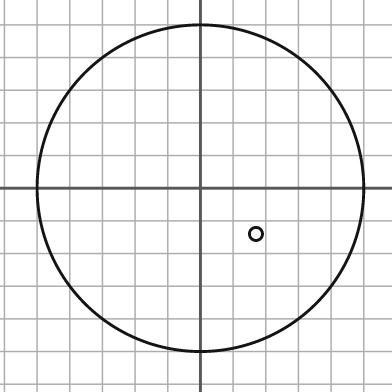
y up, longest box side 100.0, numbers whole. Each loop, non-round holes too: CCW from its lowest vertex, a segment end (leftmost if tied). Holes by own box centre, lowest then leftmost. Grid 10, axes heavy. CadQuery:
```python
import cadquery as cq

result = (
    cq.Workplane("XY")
    .moveTo(0.0, 0.0)
    .circle(50.0)
    .moveTo(17.0, -14.0)
    .circle(2.0)
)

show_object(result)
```